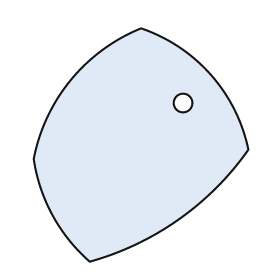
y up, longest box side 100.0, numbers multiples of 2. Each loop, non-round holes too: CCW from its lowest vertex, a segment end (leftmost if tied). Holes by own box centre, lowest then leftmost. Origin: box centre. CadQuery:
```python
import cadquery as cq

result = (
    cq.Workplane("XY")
    .moveTo(-22.0, -50.0)
    .threePointArc((16.0, -32.0), (46.0, -2.0))
    .threePointArc((30.0, 30.0), (0.0, 50.0))
    .threePointArc((-30.0, 28.0), (-46.0, -6.0))
    .threePointArc((-38.0, -30.0), (-22.0, -50.0))
    .close()
    .moveTo(18.0, 18.0)
    .circle(4.0)
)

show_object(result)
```